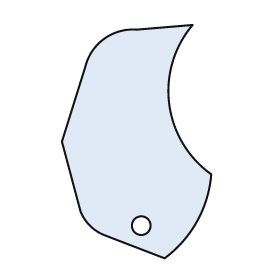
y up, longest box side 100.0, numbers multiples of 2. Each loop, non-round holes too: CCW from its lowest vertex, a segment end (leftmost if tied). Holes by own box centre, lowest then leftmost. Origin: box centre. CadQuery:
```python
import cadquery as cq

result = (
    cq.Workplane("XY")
    .moveTo(12.0, -50.0)
    .threePointArc((26.0, -34.0), (32.0, -14.0))
    .threePointArc((14.0, 16.0), (24.0, 50.0))
    .lineTo(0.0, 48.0)
    .threePointArc((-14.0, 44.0), (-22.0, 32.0))
    .lineTo(-32.0, 0.0)
    .lineTo(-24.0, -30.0)
    .threePointArc((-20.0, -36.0), (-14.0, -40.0))
    .close()
    .moveTo(2.0, -36.0)
    .circle(4.0)
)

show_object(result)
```